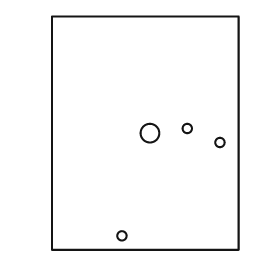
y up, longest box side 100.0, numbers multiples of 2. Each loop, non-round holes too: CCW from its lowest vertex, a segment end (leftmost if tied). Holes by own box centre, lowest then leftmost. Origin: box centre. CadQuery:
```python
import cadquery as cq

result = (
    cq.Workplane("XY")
    .moveTo(-40.0, -50.0)
    .lineTo(40.0, -50.0)
    .lineTo(40.0, 50.0)
    .lineTo(-40.0, 50.0)
    .close()
    .moveTo(-10.0, -44.0)
    .circle(2.0)
    .moveTo(32.0, -4.0)
    .circle(2.0)
    .moveTo(2.0, 0.0)
    .circle(4.0)
    .moveTo(18.0, 2.0)
    .circle(2.0)
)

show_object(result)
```